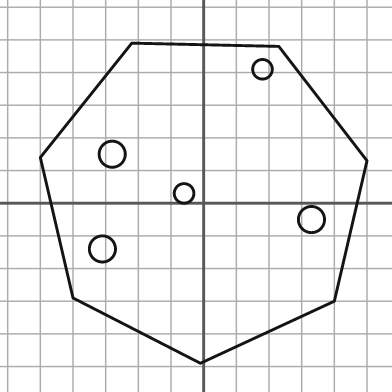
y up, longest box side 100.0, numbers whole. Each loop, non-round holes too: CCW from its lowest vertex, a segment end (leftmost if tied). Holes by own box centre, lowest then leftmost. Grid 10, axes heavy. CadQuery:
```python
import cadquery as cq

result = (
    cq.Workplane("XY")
    .moveTo(-1.0, -49.0)
    .lineTo(40.0, -30.0)
    .lineTo(50.0, 13.0)
    .lineTo(23.0, 48.0)
    .lineTo(-22.0, 49.0)
    .lineTo(-50.0, 14.0)
    .lineTo(-40.0, -29.0)
    .close()
    .moveTo(-31.0, -14.0)
    .circle(4.0)
    .moveTo(33.0, -5.0)
    .circle(4.0)
    .moveTo(-6.0, 3.0)
    .circle(3.0)
    .moveTo(-28.0, 15.0)
    .circle(4.0)
    .moveTo(18.0, 41.0)
    .circle(3.0)
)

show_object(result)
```